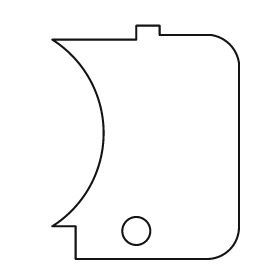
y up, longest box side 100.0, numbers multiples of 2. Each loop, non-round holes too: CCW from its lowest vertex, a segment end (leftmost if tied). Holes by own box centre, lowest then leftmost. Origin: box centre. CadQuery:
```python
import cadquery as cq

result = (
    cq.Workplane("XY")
    .moveTo(-30.0, -50.0)
    .lineTo(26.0, -50.0)
    .threePointArc((36.0, -46.0), (40.0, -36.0))
    .lineTo(40.0, 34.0)
    .threePointArc((36.0, 42.0), (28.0, 46.0))
    .lineTo(6.0, 46.0)
    .lineTo(6.0, 50.0)
    .lineTo(-4.0, 50.0)
    .lineTo(-4.0, 44.0)
    .lineTo(-40.0, 44.0)
    .threePointArc((-18.0, 4.0), (-40.0, -36.0))
    .lineTo(-30.0, -36.0)
    .close()
    .moveTo(-4.0, -38.0)
    .circle(6.0)
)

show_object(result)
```